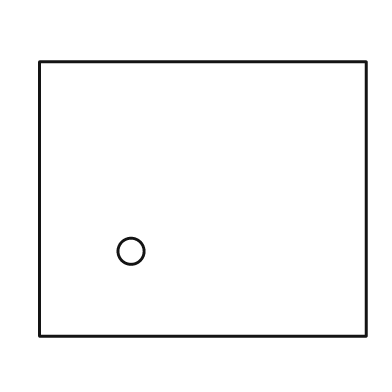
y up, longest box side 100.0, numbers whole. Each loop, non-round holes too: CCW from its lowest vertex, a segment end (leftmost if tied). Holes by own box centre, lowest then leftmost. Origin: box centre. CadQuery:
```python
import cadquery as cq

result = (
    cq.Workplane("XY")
    .moveTo(-50.0, -42.0)
    .lineTo(50.0, -42.0)
    .lineTo(50.0, 42.0)
    .lineTo(-50.0, 42.0)
    .close()
    .moveTo(-22.0, -16.0)
    .circle(4.0)
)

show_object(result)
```